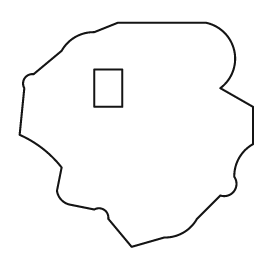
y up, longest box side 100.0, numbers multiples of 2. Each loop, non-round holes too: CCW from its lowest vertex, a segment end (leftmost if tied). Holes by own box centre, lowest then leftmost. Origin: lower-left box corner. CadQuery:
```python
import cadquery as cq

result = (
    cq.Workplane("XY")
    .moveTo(48.0, 0.0)
    .lineTo(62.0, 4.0)
    .threePointArc((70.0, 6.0), (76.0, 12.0))
    .lineTo(86.0, 22.0)
    .threePointArc((92.0, 24.0), (92.0, 30.0))
    .threePointArc((94.0, 38.0), (100.0, 44.0))
    .lineTo(100.0, 60.0)
    .lineTo(86.0, 68.0)
    .threePointArc((92.0, 84.0), (80.0, 96.0))
    .lineTo(42.0, 96.0)
    .lineTo(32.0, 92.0)
    .threePointArc((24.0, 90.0), (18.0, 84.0))
    .lineTo(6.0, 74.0)
    .threePointArc((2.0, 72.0), (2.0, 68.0))
    .lineTo(0.0, 48.0)
    .threePointArc((10.0, 42.0), (18.0, 34.0))
    .lineTo(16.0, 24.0)
    .threePointArc((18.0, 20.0), (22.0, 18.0))
    .lineTo(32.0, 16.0)
    .threePointArc((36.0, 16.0), (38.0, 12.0))
    .close()
    .moveTo(32.0, 60.0)
    .lineTo(44.0, 60.0)
    .lineTo(44.0, 76.0)
    .lineTo(32.0, 76.0)
    .close()
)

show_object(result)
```